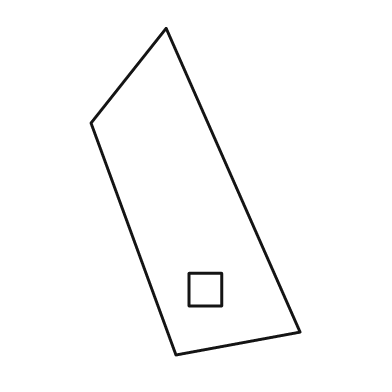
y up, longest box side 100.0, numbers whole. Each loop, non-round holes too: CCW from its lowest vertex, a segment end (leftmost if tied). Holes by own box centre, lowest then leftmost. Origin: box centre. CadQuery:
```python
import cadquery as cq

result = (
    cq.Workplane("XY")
    .moveTo(-6.0, -50.0)
    .lineTo(32.0, -43.0)
    .lineTo(-9.0, 50.0)
    .lineTo(-32.0, 21.0)
    .close()
    .moveTo(-2.0, -35.0)
    .lineTo(8.0, -35.0)
    .lineTo(8.0, -25.0)
    .lineTo(-2.0, -25.0)
    .close()
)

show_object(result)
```